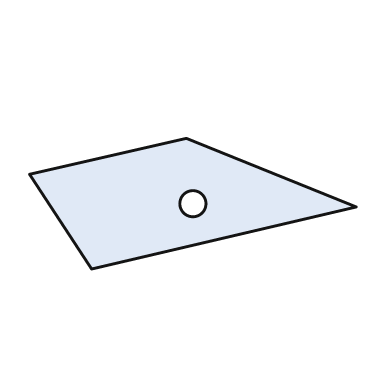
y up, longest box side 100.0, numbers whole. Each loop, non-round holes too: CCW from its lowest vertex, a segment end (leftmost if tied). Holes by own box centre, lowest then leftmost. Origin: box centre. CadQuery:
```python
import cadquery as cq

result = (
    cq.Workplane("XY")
    .moveTo(-31.0, -20.0)
    .lineTo(50.0, -1.0)
    .lineTo(-2.0, 20.0)
    .lineTo(-50.0, 9.0)
    .close()
    .moveTo(0.0, 0.0)
    .circle(4.0)
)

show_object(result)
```